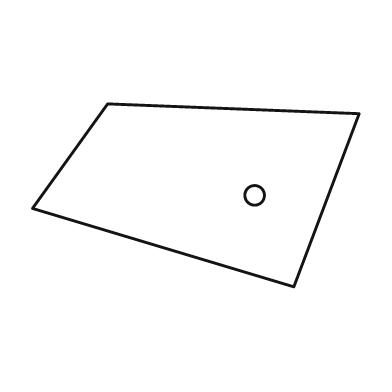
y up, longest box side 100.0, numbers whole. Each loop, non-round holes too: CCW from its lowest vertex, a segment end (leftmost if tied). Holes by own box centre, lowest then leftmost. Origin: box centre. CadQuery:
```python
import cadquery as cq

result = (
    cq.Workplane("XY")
    .moveTo(30.0, -28.0)
    .lineTo(50.0, 25.0)
    .lineTo(-27.0, 28.0)
    .lineTo(-50.0, -4.0)
    .close()
    .moveTo(18.0, 0.0)
    .circle(3.0)
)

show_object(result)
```